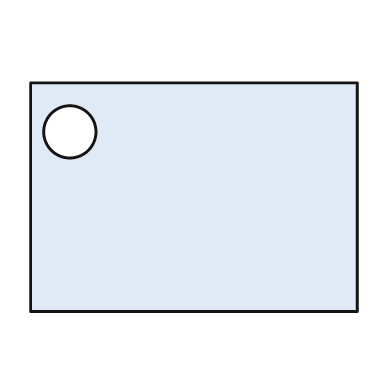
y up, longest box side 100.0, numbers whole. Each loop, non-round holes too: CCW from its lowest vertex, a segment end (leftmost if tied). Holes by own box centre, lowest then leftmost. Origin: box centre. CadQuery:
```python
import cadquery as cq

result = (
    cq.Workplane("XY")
    .moveTo(-50.0, -35.0)
    .lineTo(50.0, -35.0)
    .lineTo(50.0, 35.0)
    .lineTo(-50.0, 35.0)
    .close()
    .moveTo(-38.0, 20.0)
    .circle(8.0)
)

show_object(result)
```